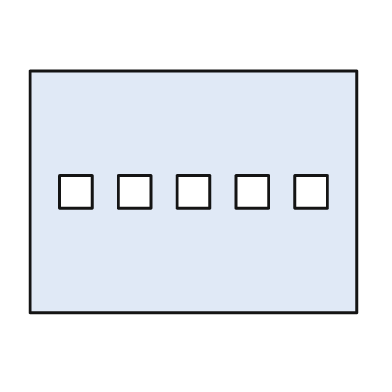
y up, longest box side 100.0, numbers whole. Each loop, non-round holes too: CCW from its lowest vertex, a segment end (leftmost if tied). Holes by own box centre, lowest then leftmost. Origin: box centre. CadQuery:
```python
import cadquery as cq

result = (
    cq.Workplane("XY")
    .moveTo(-50.0, -37.0)
    .lineTo(50.0, -37.0)
    .lineTo(50.0, 37.0)
    .lineTo(-50.0, 37.0)
    .close()
    .moveTo(-41.0, -5.0)
    .lineTo(-31.0, -5.0)
    .lineTo(-31.0, 5.0)
    .lineTo(-41.0, 5.0)
    .close()
    .moveTo(-23.0, -5.0)
    .lineTo(-13.0, -5.0)
    .lineTo(-13.0, 5.0)
    .lineTo(-23.0, 5.0)
    .close()
    .moveTo(-5.0, -5.0)
    .lineTo(5.0, -5.0)
    .lineTo(5.0, 5.0)
    .lineTo(-5.0, 5.0)
    .close()
    .moveTo(13.0, -5.0)
    .lineTo(23.0, -5.0)
    .lineTo(23.0, 5.0)
    .lineTo(13.0, 5.0)
    .close()
    .moveTo(31.0, -5.0)
    .lineTo(41.0, -5.0)
    .lineTo(41.0, 5.0)
    .lineTo(31.0, 5.0)
    .close()
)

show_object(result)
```